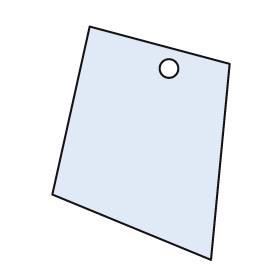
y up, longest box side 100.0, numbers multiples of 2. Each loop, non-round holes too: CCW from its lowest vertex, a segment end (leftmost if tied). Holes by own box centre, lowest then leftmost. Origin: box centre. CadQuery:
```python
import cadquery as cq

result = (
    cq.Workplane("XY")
    .moveTo(30.0, -50.0)
    .lineTo(38.0, 34.0)
    .lineTo(-22.0, 50.0)
    .lineTo(-38.0, -22.0)
    .close()
    .moveTo(12.0, 32.0)
    .circle(4.0)
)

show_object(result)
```